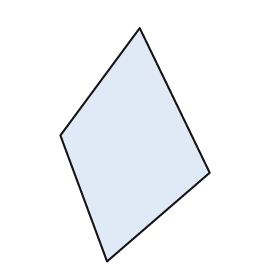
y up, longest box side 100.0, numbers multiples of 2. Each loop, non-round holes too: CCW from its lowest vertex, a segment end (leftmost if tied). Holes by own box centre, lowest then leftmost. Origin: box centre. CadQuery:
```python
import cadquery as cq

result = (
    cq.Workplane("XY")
    .moveTo(-12.0, -50.0)
    .lineTo(32.0, -12.0)
    .lineTo(2.0, 50.0)
    .lineTo(-32.0, 4.0)
    .close()
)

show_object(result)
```